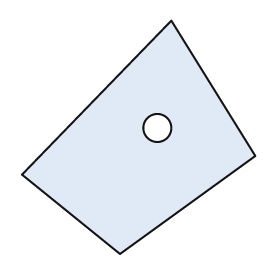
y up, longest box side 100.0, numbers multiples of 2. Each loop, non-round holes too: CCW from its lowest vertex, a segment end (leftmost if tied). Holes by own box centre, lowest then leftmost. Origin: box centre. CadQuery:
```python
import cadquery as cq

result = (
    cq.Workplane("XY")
    .moveTo(-8.0, -50.0)
    .lineTo(50.0, -8.0)
    .lineTo(14.0, 50.0)
    .lineTo(-50.0, -16.0)
    .close()
    .moveTo(8.0, 4.0)
    .circle(6.0)
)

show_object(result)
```